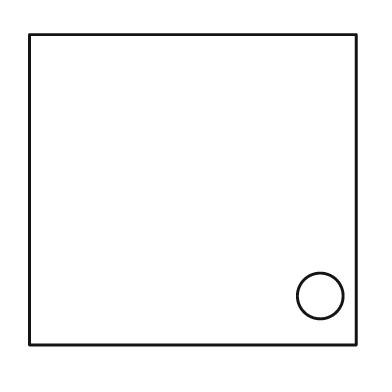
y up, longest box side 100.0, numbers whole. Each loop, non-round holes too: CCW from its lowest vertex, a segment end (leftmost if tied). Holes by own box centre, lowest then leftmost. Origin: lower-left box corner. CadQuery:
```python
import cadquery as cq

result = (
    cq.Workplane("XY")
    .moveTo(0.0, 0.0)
    .lineTo(100.0, 0.0)
    .lineTo(100.0, 95.0)
    .lineTo(0.0, 95.0)
    .close()
    .moveTo(89.0, 15.0)
    .circle(7.0)
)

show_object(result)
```